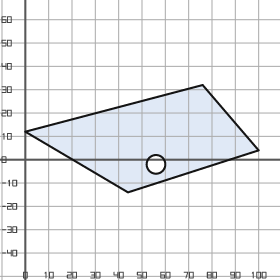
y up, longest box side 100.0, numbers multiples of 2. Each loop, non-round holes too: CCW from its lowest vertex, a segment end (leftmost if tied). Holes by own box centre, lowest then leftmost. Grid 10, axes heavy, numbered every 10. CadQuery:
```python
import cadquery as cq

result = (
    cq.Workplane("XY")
    .moveTo(44.0, -14.0)
    .lineTo(100.0, 4.0)
    .lineTo(76.0, 32.0)
    .lineTo(0.0, 12.0)
    .close()
    .moveTo(56.0, -2.0)
    .circle(4.0)
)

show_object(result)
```